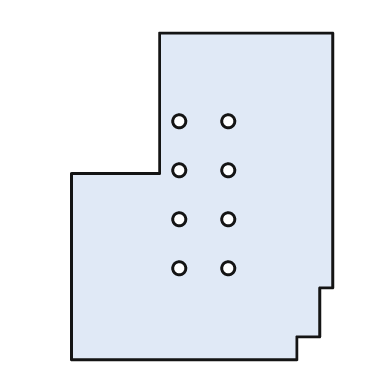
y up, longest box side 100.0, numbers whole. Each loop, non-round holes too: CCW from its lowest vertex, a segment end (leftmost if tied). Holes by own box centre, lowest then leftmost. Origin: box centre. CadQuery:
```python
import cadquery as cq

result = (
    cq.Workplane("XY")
    .moveTo(-40.0, -50.0)
    .lineTo(29.0, -50.0)
    .lineTo(29.0, -43.0)
    .lineTo(36.0, -43.0)
    .lineTo(36.0, -28.0)
    .lineTo(40.0, -28.0)
    .lineTo(40.0, 50.0)
    .lineTo(-13.0, 50.0)
    .lineTo(-13.0, 7.0)
    .lineTo(-40.0, 7.0)
    .close()
    .moveTo(-7.0, -22.0)
    .circle(2.0)
    .moveTo(8.0, -22.0)
    .circle(2.0)
    .moveTo(-7.0, -7.0)
    .circle(2.0)
    .moveTo(8.0, -7.0)
    .circle(2.0)
    .moveTo(-7.0, 8.0)
    .circle(2.0)
    .moveTo(8.0, 8.0)
    .circle(2.0)
    .moveTo(-7.0, 23.0)
    .circle(2.0)
    .moveTo(8.0, 23.0)
    .circle(2.0)
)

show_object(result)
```